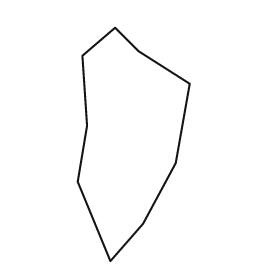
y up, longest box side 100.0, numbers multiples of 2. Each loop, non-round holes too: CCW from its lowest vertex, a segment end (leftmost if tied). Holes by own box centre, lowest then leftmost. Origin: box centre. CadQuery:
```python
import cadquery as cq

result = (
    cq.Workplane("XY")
    .moveTo(-10.0, -50.0)
    .lineTo(4.0, -34.0)
    .lineTo(18.0, -8.0)
    .lineTo(24.0, 26.0)
    .lineTo(2.0, 40.0)
    .lineTo(-8.0, 50.0)
    .lineTo(-22.0, 38.0)
    .lineTo(-20.0, 8.0)
    .lineTo(-24.0, -16.0)
    .close()
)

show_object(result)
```